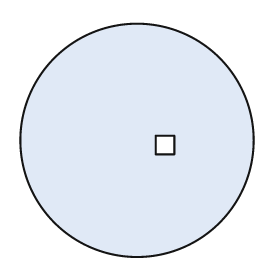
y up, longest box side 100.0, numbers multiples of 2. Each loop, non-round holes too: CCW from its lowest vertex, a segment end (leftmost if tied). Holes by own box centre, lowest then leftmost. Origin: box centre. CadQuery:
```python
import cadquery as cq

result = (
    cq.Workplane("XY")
    .moveTo(0.0, 0.0)
    .circle(50.0)
    .moveTo(8.0, -6.0)
    .lineTo(16.0, -6.0)
    .lineTo(16.0, 2.0)
    .lineTo(8.0, 2.0)
    .close()
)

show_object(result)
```